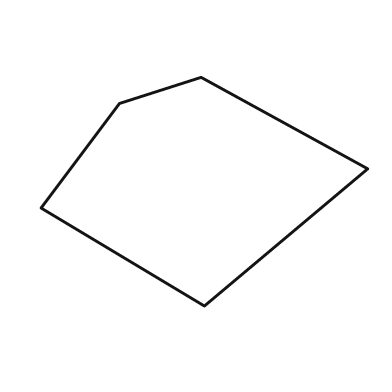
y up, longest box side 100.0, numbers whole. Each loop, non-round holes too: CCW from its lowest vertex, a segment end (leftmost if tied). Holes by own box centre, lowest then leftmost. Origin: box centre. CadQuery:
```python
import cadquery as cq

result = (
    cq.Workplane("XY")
    .moveTo(0.0, -35.0)
    .lineTo(50.0, 7.0)
    .lineTo(-1.0, 35.0)
    .lineTo(-26.0, 27.0)
    .lineTo(-50.0, -5.0)
    .close()
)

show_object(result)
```